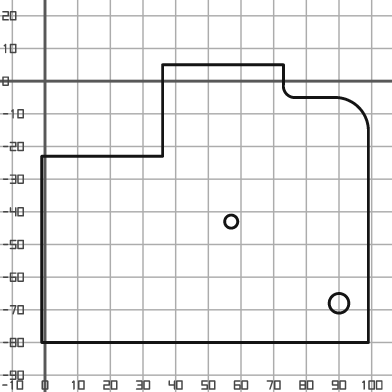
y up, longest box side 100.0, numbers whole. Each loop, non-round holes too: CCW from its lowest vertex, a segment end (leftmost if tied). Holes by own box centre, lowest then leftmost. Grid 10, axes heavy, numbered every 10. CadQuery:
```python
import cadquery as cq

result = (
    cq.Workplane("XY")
    .moveTo(-1.0, -80.0)
    .lineTo(99.0, -80.0)
    .lineTo(99.0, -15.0)
    .threePointArc((96.0, -8.0), (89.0, -5.0))
    .lineTo(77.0, -5.0)
    .threePointArc((74.0, -4.0), (73.0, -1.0))
    .lineTo(73.0, 5.0)
    .lineTo(36.0, 5.0)
    .lineTo(36.0, -23.0)
    .lineTo(-1.0, -23.0)
    .close()
    .moveTo(90.0, -68.0)
    .circle(3.0)
    .moveTo(57.0, -43.0)
    .circle(2.0)
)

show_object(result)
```